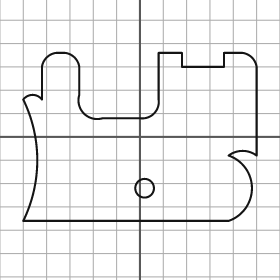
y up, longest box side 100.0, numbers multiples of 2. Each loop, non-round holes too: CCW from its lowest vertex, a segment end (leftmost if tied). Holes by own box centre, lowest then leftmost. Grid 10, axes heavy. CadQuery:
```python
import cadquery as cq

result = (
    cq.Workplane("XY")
    .moveTo(-50.0, -36.0)
    .lineTo(38.0, -36.0)
    .threePointArc((48.0, -22.0), (38.0, -8.0))
    .threePointArc((44.0, -6.0), (50.0, -8.0))
    .lineTo(50.0, 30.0)
    .threePointArc((48.0, 34.0), (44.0, 36.0))
    .lineTo(36.0, 36.0)
    .lineTo(36.0, 30.0)
    .lineTo(18.0, 30.0)
    .lineTo(18.0, 36.0)
    .lineTo(8.0, 36.0)
    .lineTo(8.0, 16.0)
    .threePointArc((6.0, 10.0), (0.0, 8.0))
    .lineTo(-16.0, 8.0)
    .threePointArc((-24.0, 10.0), (-26.0, 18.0))
    .lineTo(-26.0, 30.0)
    .threePointArc((-28.0, 34.0), (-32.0, 36.0))
    .lineTo(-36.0, 36.0)
    .threePointArc((-40.0, 34.0), (-42.0, 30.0))
    .lineTo(-42.0, 16.0)
    .threePointArc((-46.0, 18.0), (-50.0, 16.0))
    .threePointArc((-44.0, -10.0), (-50.0, -36.0))
    .close()
    .moveTo(2.0, -22.0)
    .circle(4.0)
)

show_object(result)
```